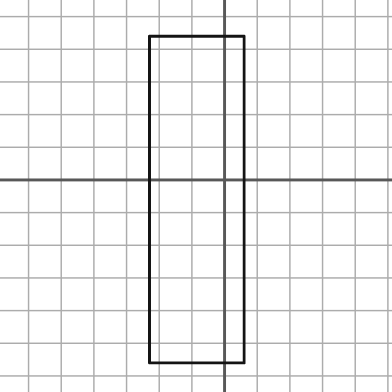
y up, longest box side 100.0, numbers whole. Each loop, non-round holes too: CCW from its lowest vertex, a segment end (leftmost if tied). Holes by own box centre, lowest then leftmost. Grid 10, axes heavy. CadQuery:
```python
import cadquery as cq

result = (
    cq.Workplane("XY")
    .moveTo(-23.0, -56.0)
    .lineTo(6.0, -56.0)
    .lineTo(6.0, 44.0)
    .lineTo(-23.0, 44.0)
    .close()
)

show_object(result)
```